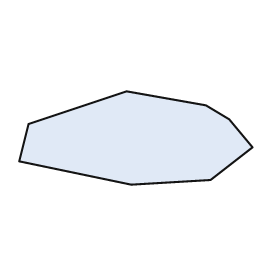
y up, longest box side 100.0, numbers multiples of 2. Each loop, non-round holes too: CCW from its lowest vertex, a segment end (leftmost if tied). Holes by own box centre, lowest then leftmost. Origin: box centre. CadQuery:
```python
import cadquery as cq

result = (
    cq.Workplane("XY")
    .moveTo(-2.0, -20.0)
    .lineTo(32.0, -18.0)
    .lineTo(50.0, -4.0)
    .lineTo(40.0, 8.0)
    .lineTo(30.0, 14.0)
    .lineTo(-4.0, 20.0)
    .lineTo(-46.0, 6.0)
    .lineTo(-50.0, -10.0)
    .close()
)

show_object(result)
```